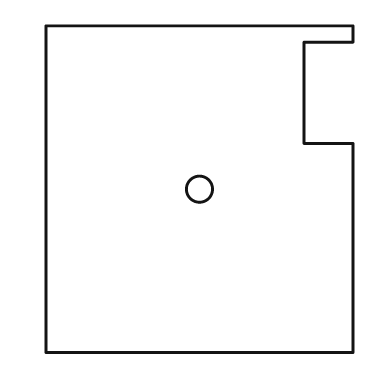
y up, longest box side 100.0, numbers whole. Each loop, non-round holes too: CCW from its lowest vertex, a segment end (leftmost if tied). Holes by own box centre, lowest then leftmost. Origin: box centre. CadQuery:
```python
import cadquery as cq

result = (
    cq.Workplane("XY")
    .moveTo(-47.0, -50.0)
    .lineTo(47.0, -50.0)
    .lineTo(47.0, 14.0)
    .lineTo(32.0, 14.0)
    .lineTo(32.0, 45.0)
    .lineTo(47.0, 45.0)
    .lineTo(47.0, 50.0)
    .lineTo(-47.0, 50.0)
    .close()
    .moveTo(0.0, 0.0)
    .circle(4.0)
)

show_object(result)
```